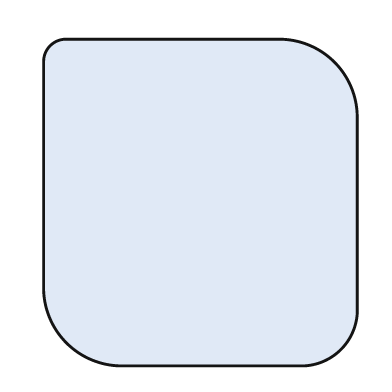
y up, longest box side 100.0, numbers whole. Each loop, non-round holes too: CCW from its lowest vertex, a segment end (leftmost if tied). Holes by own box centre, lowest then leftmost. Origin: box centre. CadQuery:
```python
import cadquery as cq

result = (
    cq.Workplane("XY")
    .moveTo(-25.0, -50.0)
    .lineTo(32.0, -50.0)
    .threePointArc((43.0, -45.0), (48.0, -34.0))
    .lineTo(48.0, 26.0)
    .threePointArc((41.0, 43.0), (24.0, 50.0))
    .lineTo(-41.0, 50.0)
    .threePointArc((-46.0, 48.0), (-48.0, 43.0))
    .lineTo(-48.0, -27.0)
    .threePointArc((-41.0, -43.0), (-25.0, -50.0))
    .close()
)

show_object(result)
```